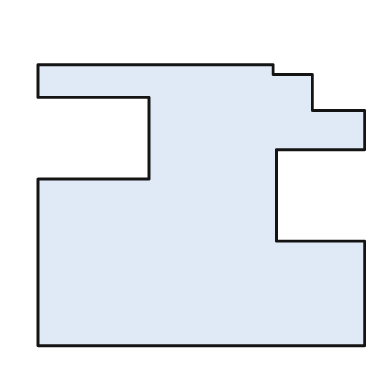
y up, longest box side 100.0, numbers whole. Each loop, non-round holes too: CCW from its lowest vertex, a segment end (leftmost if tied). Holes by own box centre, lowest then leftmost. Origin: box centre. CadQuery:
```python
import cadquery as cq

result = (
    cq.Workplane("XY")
    .moveTo(-50.0, -43.0)
    .lineTo(50.0, -43.0)
    .lineTo(50.0, -11.0)
    .lineTo(23.0, -11.0)
    .lineTo(23.0, 17.0)
    .lineTo(50.0, 17.0)
    .lineTo(50.0, 29.0)
    .lineTo(34.0, 29.0)
    .lineTo(34.0, 40.0)
    .lineTo(22.0, 40.0)
    .lineTo(22.0, 43.0)
    .lineTo(-50.0, 43.0)
    .lineTo(-50.0, 33.0)
    .lineTo(-16.0, 33.0)
    .lineTo(-16.0, 8.0)
    .lineTo(-50.0, 8.0)
    .close()
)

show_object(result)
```